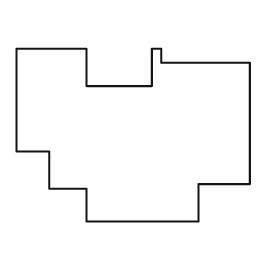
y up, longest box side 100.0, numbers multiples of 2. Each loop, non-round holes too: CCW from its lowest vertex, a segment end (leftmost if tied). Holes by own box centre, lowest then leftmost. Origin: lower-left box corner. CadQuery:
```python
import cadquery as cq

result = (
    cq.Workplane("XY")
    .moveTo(30.0, 0.0)
    .lineTo(78.0, 0.0)
    .lineTo(78.0, 16.0)
    .lineTo(100.0, 16.0)
    .lineTo(100.0, 68.0)
    .lineTo(62.0, 68.0)
    .lineTo(62.0, 74.0)
    .lineTo(58.0, 74.0)
    .lineTo(58.0, 58.0)
    .lineTo(30.0, 58.0)
    .lineTo(30.0, 74.0)
    .lineTo(0.0, 74.0)
    .lineTo(0.0, 30.0)
    .lineTo(14.0, 30.0)
    .lineTo(14.0, 14.0)
    .lineTo(30.0, 14.0)
    .close()
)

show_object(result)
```